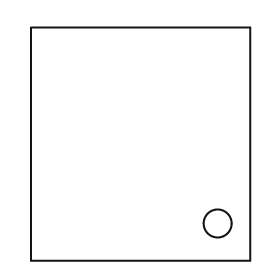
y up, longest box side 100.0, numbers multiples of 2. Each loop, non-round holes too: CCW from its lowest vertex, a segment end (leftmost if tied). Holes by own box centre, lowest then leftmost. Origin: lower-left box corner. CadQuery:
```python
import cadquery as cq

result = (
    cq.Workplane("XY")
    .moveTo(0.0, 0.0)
    .lineTo(94.0, 0.0)
    .lineTo(94.0, 100.0)
    .lineTo(0.0, 100.0)
    .close()
    .moveTo(80.0, 16.0)
    .circle(6.0)
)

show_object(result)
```